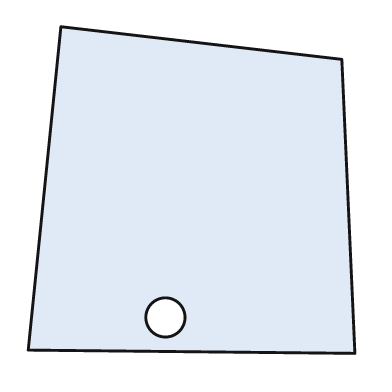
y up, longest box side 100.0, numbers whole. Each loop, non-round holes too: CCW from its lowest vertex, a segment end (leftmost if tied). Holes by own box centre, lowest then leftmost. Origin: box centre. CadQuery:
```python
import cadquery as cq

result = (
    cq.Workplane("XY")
    .moveTo(50.0, -50.0)
    .lineTo(46.0, 40.0)
    .lineTo(-40.0, 50.0)
    .lineTo(-50.0, -49.0)
    .close()
    .moveTo(-8.0, -39.0)
    .circle(6.0)
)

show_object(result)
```